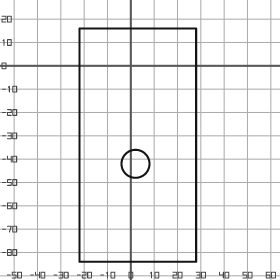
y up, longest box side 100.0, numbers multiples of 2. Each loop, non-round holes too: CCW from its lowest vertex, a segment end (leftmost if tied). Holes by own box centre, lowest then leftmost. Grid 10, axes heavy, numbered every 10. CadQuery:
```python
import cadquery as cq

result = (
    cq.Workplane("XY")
    .moveTo(-22.0, -84.0)
    .lineTo(28.0, -84.0)
    .lineTo(28.0, 16.0)
    .lineTo(-22.0, 16.0)
    .close()
    .moveTo(2.0, -42.0)
    .circle(6.0)
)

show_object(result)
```